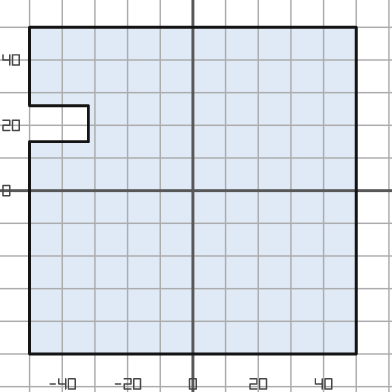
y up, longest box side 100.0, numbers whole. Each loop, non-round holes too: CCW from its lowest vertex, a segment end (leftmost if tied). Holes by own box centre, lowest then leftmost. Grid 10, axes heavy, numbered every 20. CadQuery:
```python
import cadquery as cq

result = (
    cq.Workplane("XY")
    .moveTo(-50.0, -50.0)
    .lineTo(50.0, -50.0)
    .lineTo(50.0, 50.0)
    .lineTo(-50.0, 50.0)
    .lineTo(-50.0, 26.0)
    .lineTo(-32.0, 26.0)
    .lineTo(-32.0, 15.0)
    .lineTo(-50.0, 15.0)
    .close()
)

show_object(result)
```